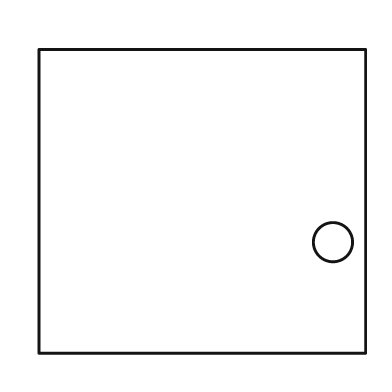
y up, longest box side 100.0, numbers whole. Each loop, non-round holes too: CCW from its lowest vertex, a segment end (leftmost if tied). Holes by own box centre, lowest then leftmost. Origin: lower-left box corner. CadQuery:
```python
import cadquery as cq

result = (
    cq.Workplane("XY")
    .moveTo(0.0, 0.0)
    .lineTo(100.0, 0.0)
    .lineTo(100.0, 93.0)
    .lineTo(0.0, 93.0)
    .close()
    .moveTo(90.0, 34.0)
    .circle(6.0)
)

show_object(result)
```